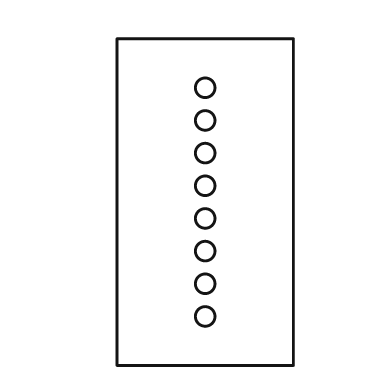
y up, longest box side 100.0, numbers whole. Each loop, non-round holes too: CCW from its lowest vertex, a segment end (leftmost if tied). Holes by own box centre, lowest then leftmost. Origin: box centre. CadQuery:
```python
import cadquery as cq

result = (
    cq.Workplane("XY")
    .moveTo(-27.0, -50.0)
    .lineTo(27.0, -50.0)
    .lineTo(27.0, 50.0)
    .lineTo(-27.0, 50.0)
    .close()
    .moveTo(0.0, -35.0)
    .circle(3.0)
    .moveTo(0.0, -25.0)
    .circle(3.0)
    .moveTo(0.0, -15.0)
    .circle(3.0)
    .moveTo(0.0, -5.0)
    .circle(3.0)
    .moveTo(0.0, 5.0)
    .circle(3.0)
    .moveTo(0.0, 15.0)
    .circle(3.0)
    .moveTo(0.0, 25.0)
    .circle(3.0)
    .moveTo(0.0, 35.0)
    .circle(3.0)
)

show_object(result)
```